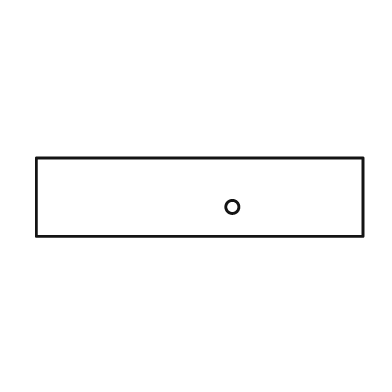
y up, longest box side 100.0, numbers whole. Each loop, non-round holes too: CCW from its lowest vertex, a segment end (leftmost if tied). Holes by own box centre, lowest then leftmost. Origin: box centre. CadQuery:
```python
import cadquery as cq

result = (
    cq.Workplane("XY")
    .moveTo(-50.0, -12.0)
    .lineTo(50.0, -12.0)
    .lineTo(50.0, 12.0)
    .lineTo(-50.0, 12.0)
    .close()
    .moveTo(10.0, -3.0)
    .circle(2.0)
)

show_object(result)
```